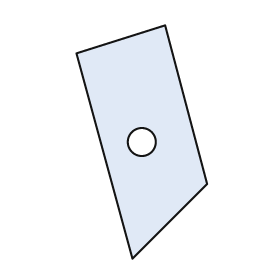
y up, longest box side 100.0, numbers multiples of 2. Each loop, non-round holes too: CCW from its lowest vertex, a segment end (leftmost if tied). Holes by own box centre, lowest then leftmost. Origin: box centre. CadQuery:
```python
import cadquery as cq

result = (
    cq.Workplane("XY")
    .moveTo(-4.0, -50.0)
    .lineTo(28.0, -18.0)
    .lineTo(10.0, 50.0)
    .lineTo(-28.0, 38.0)
    .close()
    .moveTo(0.0, 0.0)
    .circle(6.0)
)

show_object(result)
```